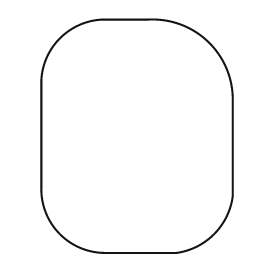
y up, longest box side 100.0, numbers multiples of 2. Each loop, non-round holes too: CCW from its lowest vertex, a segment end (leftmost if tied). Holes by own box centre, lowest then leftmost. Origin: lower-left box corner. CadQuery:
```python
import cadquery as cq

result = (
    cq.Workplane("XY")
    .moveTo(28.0, 0.0)
    .lineTo(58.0, 0.0)
    .threePointArc((74.0, 8.0), (82.0, 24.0))
    .lineTo(82.0, 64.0)
    .threePointArc((72.0, 90.0), (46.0, 100.0))
    .lineTo(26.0, 100.0)
    .threePointArc((8.0, 92.0), (0.0, 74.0))
    .lineTo(0.0, 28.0)
    .threePointArc((8.0, 8.0), (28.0, 0.0))
    .close()
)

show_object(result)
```